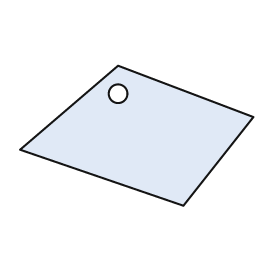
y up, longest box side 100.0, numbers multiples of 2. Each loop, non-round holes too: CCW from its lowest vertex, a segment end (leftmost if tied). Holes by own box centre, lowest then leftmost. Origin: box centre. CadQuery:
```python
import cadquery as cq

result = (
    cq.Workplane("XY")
    .moveTo(20.0, -30.0)
    .lineTo(50.0, 8.0)
    .lineTo(-8.0, 30.0)
    .lineTo(-50.0, -6.0)
    .close()
    .moveTo(-8.0, 18.0)
    .circle(4.0)
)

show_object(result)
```